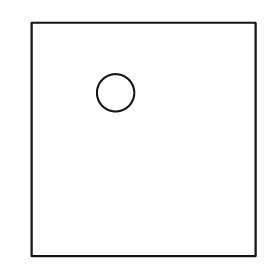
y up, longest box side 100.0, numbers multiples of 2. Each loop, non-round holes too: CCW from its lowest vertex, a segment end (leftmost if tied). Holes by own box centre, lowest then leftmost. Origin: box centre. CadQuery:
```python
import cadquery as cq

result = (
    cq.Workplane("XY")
    .moveTo(-48.0, -50.0)
    .lineTo(48.0, -50.0)
    .lineTo(48.0, 50.0)
    .lineTo(-48.0, 50.0)
    .close()
    .moveTo(-12.0, 20.0)
    .circle(8.0)
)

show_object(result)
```